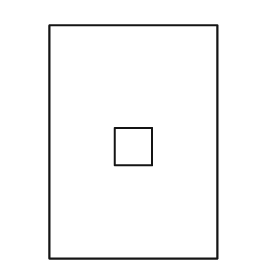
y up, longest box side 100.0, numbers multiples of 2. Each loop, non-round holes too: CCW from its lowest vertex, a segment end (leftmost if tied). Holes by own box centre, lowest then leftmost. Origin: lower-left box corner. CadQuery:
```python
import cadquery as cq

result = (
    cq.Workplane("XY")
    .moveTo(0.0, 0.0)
    .lineTo(72.0, 0.0)
    .lineTo(72.0, 100.0)
    .lineTo(0.0, 100.0)
    .close()
    .moveTo(28.0, 40.0)
    .lineTo(44.0, 40.0)
    .lineTo(44.0, 56.0)
    .lineTo(28.0, 56.0)
    .close()
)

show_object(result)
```